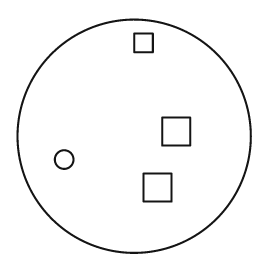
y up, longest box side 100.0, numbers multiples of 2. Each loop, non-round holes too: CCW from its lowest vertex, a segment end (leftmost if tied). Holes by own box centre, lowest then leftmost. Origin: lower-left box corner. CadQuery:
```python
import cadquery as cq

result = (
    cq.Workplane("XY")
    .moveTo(50.0, 50.0)
    .circle(50.0)
    .moveTo(54.0, 22.0)
    .lineTo(66.0, 22.0)
    .lineTo(66.0, 34.0)
    .lineTo(54.0, 34.0)
    .close()
    .moveTo(20.0, 40.0)
    .circle(4.0)
    .moveTo(62.0, 46.0)
    .lineTo(74.0, 46.0)
    .lineTo(74.0, 58.0)
    .lineTo(62.0, 58.0)
    .close()
    .moveTo(50.0, 86.0)
    .lineTo(58.0, 86.0)
    .lineTo(58.0, 94.0)
    .lineTo(50.0, 94.0)
    .close()
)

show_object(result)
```